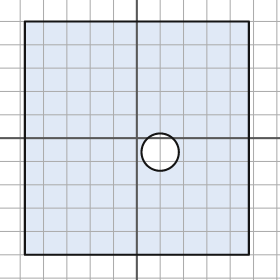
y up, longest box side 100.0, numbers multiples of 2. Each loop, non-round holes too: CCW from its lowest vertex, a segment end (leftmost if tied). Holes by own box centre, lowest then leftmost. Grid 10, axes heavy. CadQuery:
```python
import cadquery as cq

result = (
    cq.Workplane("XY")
    .moveTo(-48.0, -50.0)
    .lineTo(48.0, -50.0)
    .lineTo(48.0, 50.0)
    .lineTo(-48.0, 50.0)
    .close()
    .moveTo(10.0, -6.0)
    .circle(8.0)
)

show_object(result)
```